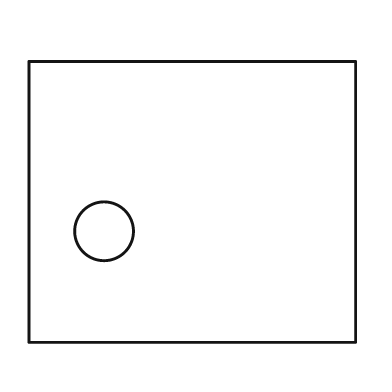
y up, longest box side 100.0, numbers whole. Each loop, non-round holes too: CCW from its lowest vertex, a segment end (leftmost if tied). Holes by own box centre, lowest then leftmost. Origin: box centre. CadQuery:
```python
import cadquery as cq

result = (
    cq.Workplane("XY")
    .moveTo(-50.0, -43.0)
    .lineTo(50.0, -43.0)
    .lineTo(50.0, 43.0)
    .lineTo(-50.0, 43.0)
    .close()
    .moveTo(-27.0, -9.0)
    .circle(9.0)
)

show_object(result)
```